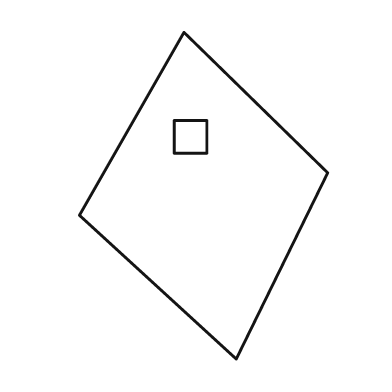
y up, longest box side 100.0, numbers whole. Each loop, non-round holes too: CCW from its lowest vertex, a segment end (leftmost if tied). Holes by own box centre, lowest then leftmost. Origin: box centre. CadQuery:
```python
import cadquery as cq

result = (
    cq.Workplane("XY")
    .moveTo(10.0, -50.0)
    .lineTo(38.0, 7.0)
    .lineTo(-6.0, 50.0)
    .lineTo(-38.0, -6.0)
    .close()
    .moveTo(-9.0, 13.0)
    .lineTo(1.0, 13.0)
    .lineTo(1.0, 23.0)
    .lineTo(-9.0, 23.0)
    .close()
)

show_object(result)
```